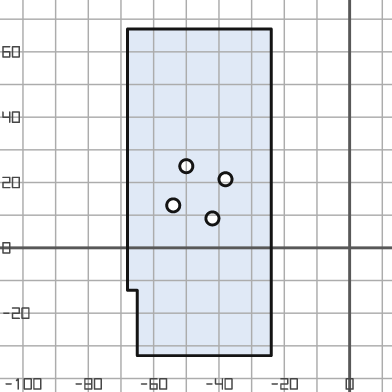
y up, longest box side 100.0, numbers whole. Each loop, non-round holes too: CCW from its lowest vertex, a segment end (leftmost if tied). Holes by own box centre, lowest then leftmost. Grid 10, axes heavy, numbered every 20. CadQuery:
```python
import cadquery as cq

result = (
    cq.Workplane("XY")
    .moveTo(-65.0, -33.0)
    .lineTo(-24.0, -33.0)
    .lineTo(-24.0, 67.0)
    .lineTo(-68.0, 67.0)
    .lineTo(-68.0, -13.0)
    .lineTo(-65.0, -13.0)
    .close()
    .moveTo(-42.0, 9.0)
    .circle(2.0)
    .moveTo(-54.0, 13.0)
    .circle(2.0)
    .moveTo(-38.0, 21.0)
    .circle(2.0)
    .moveTo(-50.0, 25.0)
    .circle(2.0)
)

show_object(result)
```